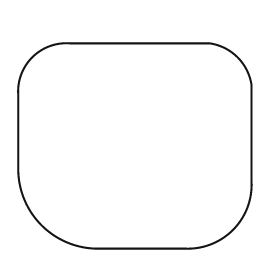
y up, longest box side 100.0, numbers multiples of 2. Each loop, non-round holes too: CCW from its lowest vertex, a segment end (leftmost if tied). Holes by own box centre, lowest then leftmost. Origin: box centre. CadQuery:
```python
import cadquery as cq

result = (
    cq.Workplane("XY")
    .moveTo(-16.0, -44.0)
    .lineTo(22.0, -44.0)
    .threePointArc((42.0, -36.0), (50.0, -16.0))
    .lineTo(50.0, 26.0)
    .threePointArc((44.0, 38.0), (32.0, 44.0))
    .lineTo(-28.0, 44.0)
    .threePointArc((-44.0, 38.0), (-50.0, 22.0))
    .lineTo(-50.0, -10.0)
    .threePointArc((-40.0, -34.0), (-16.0, -44.0))
    .close()
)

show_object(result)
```